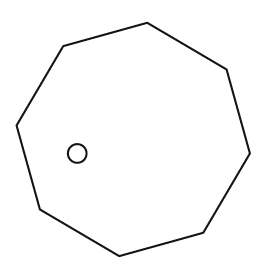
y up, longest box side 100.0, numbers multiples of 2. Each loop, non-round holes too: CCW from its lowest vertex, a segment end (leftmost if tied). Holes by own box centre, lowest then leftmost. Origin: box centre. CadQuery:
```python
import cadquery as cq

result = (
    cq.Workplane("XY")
    .moveTo(-6.0, -50.0)
    .lineTo(30.0, -40.0)
    .lineTo(50.0, -6.0)
    .lineTo(40.0, 30.0)
    .lineTo(6.0, 50.0)
    .lineTo(-30.0, 40.0)
    .lineTo(-50.0, 6.0)
    .lineTo(-40.0, -30.0)
    .close()
    .moveTo(-24.0, -6.0)
    .circle(4.0)
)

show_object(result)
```